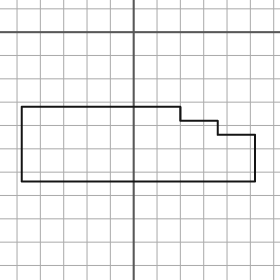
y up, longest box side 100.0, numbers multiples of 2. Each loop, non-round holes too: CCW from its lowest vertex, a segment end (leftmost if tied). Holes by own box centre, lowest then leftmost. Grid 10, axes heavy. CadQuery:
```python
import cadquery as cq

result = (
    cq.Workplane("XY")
    .moveTo(-48.0, -64.0)
    .lineTo(52.0, -64.0)
    .lineTo(52.0, -44.0)
    .lineTo(36.0, -44.0)
    .lineTo(36.0, -38.0)
    .lineTo(20.0, -38.0)
    .lineTo(20.0, -32.0)
    .lineTo(-48.0, -32.0)
    .close()
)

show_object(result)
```